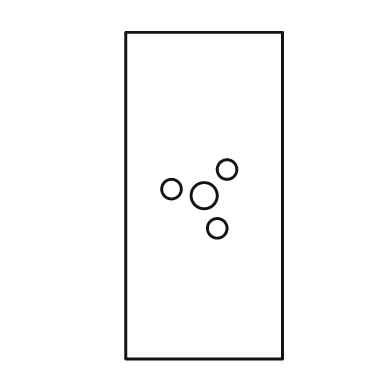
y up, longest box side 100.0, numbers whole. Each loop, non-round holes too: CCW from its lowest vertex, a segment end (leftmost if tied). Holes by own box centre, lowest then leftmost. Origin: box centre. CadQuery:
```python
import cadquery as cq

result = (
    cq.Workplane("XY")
    .moveTo(-24.0, -50.0)
    .lineTo(24.0, -50.0)
    .lineTo(24.0, 50.0)
    .lineTo(-24.0, 50.0)
    .close()
    .moveTo(4.0, -10.0)
    .circle(3.0)
    .moveTo(0.0, 0.0)
    .circle(4.0)
    .moveTo(-10.0, 2.0)
    .circle(3.0)
    .moveTo(7.0, 8.0)
    .circle(3.0)
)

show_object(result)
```